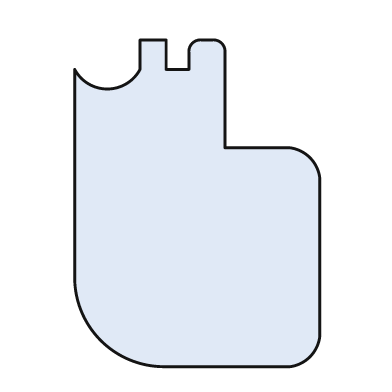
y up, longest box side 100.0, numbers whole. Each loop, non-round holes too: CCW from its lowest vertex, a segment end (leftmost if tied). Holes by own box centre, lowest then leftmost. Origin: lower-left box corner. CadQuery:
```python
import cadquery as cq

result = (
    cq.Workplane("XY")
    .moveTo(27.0, 0.0)
    .lineTo(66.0, 0.0)
    .threePointArc((72.0, 3.0), (75.0, 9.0))
    .lineTo(75.0, 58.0)
    .threePointArc((72.0, 64.0), (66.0, 67.0))
    .lineTo(46.0, 67.0)
    .lineTo(46.0, 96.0)
    .threePointArc((45.0, 99.0), (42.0, 100.0))
    .lineTo(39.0, 100.0)
    .threePointArc((36.0, 99.0), (35.0, 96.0))
    .lineTo(35.0, 91.0)
    .lineTo(28.0, 91.0)
    .lineTo(28.0, 100.0)
    .lineTo(20.0, 100.0)
    .lineTo(20.0, 91.0)
    .threePointArc((10.0, 85.0), (0.0, 91.0))
    .lineTo(0.0, 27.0)
    .threePointArc((8.0, 8.0), (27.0, 0.0))
    .close()
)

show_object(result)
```